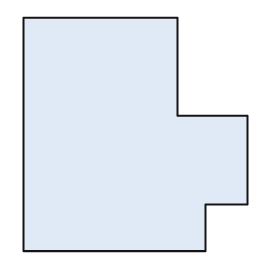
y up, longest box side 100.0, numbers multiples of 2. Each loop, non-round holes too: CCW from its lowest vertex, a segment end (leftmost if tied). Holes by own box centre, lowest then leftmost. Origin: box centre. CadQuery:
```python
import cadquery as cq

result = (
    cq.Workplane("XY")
    .moveTo(-48.0, -50.0)
    .lineTo(30.0, -50.0)
    .lineTo(30.0, -30.0)
    .lineTo(48.0, -30.0)
    .lineTo(48.0, 8.0)
    .lineTo(18.0, 8.0)
    .lineTo(18.0, 50.0)
    .lineTo(-48.0, 50.0)
    .close()
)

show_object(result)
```